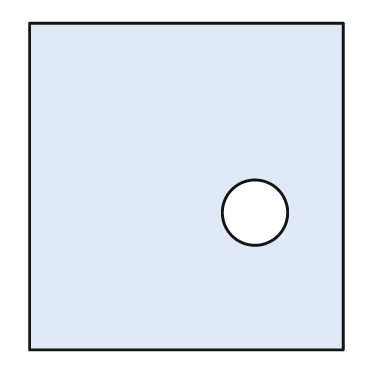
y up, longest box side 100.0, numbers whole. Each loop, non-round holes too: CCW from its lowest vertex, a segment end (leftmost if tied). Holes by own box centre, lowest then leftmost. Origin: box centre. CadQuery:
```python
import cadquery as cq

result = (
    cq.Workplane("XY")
    .moveTo(-48.0, -50.0)
    .lineTo(48.0, -50.0)
    .lineTo(48.0, 50.0)
    .lineTo(-48.0, 50.0)
    .close()
    .moveTo(21.0, -8.0)
    .circle(10.0)
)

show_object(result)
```